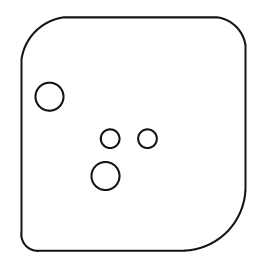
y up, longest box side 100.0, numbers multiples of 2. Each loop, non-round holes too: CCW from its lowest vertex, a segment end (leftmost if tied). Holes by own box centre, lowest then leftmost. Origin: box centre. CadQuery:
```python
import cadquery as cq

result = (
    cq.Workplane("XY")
    .moveTo(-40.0, -50.0)
    .lineTo(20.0, -50.0)
    .threePointArc((40.0, -42.0), (48.0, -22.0))
    .lineTo(48.0, 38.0)
    .threePointArc((44.0, 46.0), (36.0, 50.0))
    .lineTo(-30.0, 50.0)
    .threePointArc((-42.0, 44.0), (-48.0, 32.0))
    .lineTo(-48.0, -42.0)
    .threePointArc((-46.0, -48.0), (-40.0, -50.0))
    .close()
    .moveTo(-12.0, -18.0)
    .circle(6.0)
    .moveTo(-10.0, -2.0)
    .circle(4.0)
    .moveTo(6.0, -2.0)
    .circle(4.0)
    .moveTo(-36.0, 16.0)
    .circle(6.0)
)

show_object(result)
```